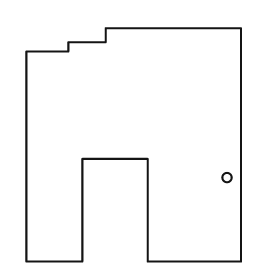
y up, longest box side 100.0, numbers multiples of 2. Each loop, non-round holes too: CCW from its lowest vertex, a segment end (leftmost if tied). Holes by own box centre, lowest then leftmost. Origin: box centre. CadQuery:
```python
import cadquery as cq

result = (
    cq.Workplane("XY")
    .moveTo(-46.0, -50.0)
    .lineTo(-22.0, -50.0)
    .lineTo(-22.0, -6.0)
    .lineTo(6.0, -6.0)
    .lineTo(6.0, -50.0)
    .lineTo(46.0, -50.0)
    .lineTo(46.0, 50.0)
    .lineTo(-12.0, 50.0)
    .lineTo(-12.0, 44.0)
    .lineTo(-28.0, 44.0)
    .lineTo(-28.0, 40.0)
    .lineTo(-46.0, 40.0)
    .close()
    .moveTo(40.0, -14.0)
    .circle(2.0)
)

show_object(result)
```